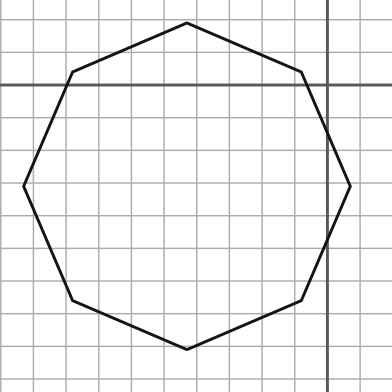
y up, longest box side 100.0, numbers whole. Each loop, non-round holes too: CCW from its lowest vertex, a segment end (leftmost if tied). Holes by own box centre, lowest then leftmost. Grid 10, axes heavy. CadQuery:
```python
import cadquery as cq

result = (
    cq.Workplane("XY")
    .moveTo(-43.0, -81.0)
    .lineTo(-8.0, -66.0)
    .lineTo(7.0, -31.0)
    .lineTo(-8.0, 4.0)
    .lineTo(-43.0, 19.0)
    .lineTo(-78.0, 4.0)
    .lineTo(-93.0, -31.0)
    .lineTo(-78.0, -66.0)
    .close()
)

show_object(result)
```